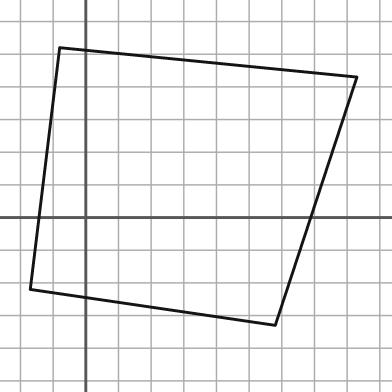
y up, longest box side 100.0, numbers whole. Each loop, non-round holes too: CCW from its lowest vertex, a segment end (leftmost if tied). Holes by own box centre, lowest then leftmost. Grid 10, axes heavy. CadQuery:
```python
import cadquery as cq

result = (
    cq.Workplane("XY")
    .moveTo(58.0, -33.0)
    .lineTo(83.0, 43.0)
    .lineTo(-8.0, 52.0)
    .lineTo(-17.0, -22.0)
    .close()
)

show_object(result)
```